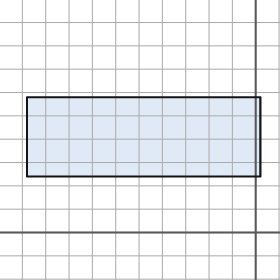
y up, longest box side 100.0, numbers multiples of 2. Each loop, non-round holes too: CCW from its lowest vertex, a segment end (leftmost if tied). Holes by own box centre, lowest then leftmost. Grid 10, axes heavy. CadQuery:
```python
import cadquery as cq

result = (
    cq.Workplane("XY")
    .moveTo(-98.0, 24.0)
    .lineTo(2.0, 24.0)
    .lineTo(2.0, 58.0)
    .lineTo(-98.0, 58.0)
    .close()
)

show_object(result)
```